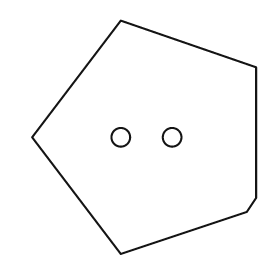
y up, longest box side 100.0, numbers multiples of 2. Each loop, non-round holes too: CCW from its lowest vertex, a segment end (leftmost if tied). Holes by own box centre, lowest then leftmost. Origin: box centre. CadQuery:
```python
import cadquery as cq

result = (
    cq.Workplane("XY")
    .moveTo(-10.0, -50.0)
    .lineTo(44.0, -32.0)
    .lineTo(48.0, -26.0)
    .lineTo(48.0, 30.0)
    .lineTo(-10.0, 50.0)
    .lineTo(-48.0, 0.0)
    .close()
    .moveTo(-10.0, 0.0)
    .circle(4.0)
    .moveTo(12.0, 0.0)
    .circle(4.0)
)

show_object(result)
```